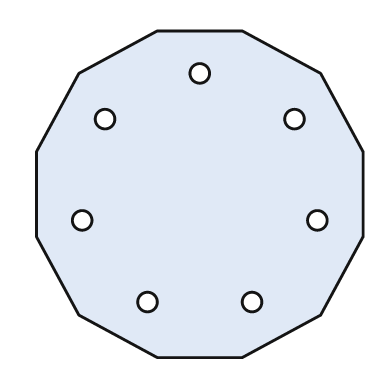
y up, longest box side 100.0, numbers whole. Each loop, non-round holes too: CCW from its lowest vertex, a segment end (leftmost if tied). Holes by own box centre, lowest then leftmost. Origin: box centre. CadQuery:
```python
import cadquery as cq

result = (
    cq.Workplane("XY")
    .moveTo(-13.0, -50.0)
    .lineTo(13.0, -50.0)
    .lineTo(37.0, -37.0)
    .lineTo(50.0, -13.0)
    .lineTo(50.0, 13.0)
    .lineTo(37.0, 37.0)
    .lineTo(13.0, 50.0)
    .lineTo(-13.0, 50.0)
    .lineTo(-37.0, 37.0)
    .lineTo(-50.0, 13.0)
    .lineTo(-50.0, -13.0)
    .lineTo(-37.0, -37.0)
    .close()
    .moveTo(-16.0, -33.0)
    .circle(3.0)
    .moveTo(16.0, -33.0)
    .circle(3.0)
    .moveTo(-36.0, -8.0)
    .circle(3.0)
    .moveTo(36.0, -8.0)
    .circle(3.0)
    .moveTo(-29.0, 23.0)
    .circle(3.0)
    .moveTo(29.0, 23.0)
    .circle(3.0)
    .moveTo(0.0, 37.0)
    .circle(3.0)
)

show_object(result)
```